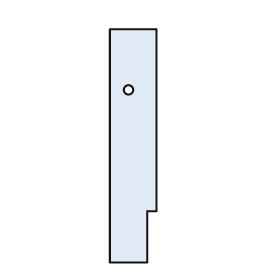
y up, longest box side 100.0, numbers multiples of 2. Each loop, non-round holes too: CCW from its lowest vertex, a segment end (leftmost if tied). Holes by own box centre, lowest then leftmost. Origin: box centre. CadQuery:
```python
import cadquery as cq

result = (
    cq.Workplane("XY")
    .moveTo(-10.0, -50.0)
    .lineTo(6.0, -50.0)
    .lineTo(6.0, -28.0)
    .lineTo(10.0, -28.0)
    .lineTo(10.0, 50.0)
    .lineTo(-10.0, 50.0)
    .close()
    .moveTo(-2.0, 24.0)
    .circle(2.0)
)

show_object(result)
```